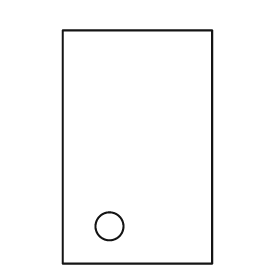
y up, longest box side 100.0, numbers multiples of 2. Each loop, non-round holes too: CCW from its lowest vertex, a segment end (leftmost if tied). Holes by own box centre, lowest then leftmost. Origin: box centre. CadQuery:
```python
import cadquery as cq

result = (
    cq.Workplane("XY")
    .moveTo(-32.0, -50.0)
    .lineTo(32.0, -50.0)
    .lineTo(32.0, 50.0)
    .lineTo(-32.0, 50.0)
    .close()
    .moveTo(-12.0, -34.0)
    .circle(6.0)
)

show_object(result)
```